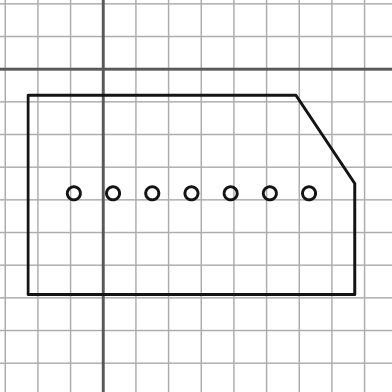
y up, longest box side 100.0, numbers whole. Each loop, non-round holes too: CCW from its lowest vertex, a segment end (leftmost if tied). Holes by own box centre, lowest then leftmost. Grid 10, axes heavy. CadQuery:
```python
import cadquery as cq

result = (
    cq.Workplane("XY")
    .moveTo(-23.0, -69.0)
    .lineTo(77.0, -69.0)
    .lineTo(77.0, -35.0)
    .lineTo(59.0, -8.0)
    .lineTo(-23.0, -8.0)
    .close()
    .moveTo(-9.0, -38.0)
    .circle(2.0)
    .moveTo(3.0, -38.0)
    .circle(2.0)
    .moveTo(15.0, -38.0)
    .circle(2.0)
    .moveTo(27.0, -38.0)
    .circle(2.0)
    .moveTo(39.0, -38.0)
    .circle(2.0)
    .moveTo(51.0, -38.0)
    .circle(2.0)
    .moveTo(63.0, -38.0)
    .circle(2.0)
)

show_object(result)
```